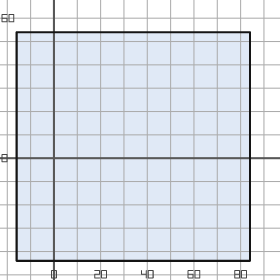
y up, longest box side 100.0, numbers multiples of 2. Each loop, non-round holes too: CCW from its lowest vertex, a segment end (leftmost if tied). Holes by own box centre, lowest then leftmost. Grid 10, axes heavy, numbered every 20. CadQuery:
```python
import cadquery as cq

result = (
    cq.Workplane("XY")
    .moveTo(-16.0, -44.0)
    .lineTo(84.0, -44.0)
    .lineTo(84.0, 54.0)
    .lineTo(-16.0, 54.0)
    .close()
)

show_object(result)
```